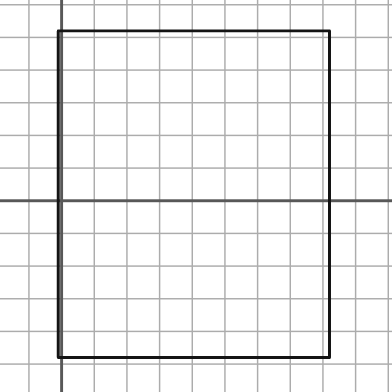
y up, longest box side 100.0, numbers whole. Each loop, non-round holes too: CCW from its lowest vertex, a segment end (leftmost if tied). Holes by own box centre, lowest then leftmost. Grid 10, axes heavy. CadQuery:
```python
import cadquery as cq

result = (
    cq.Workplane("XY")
    .moveTo(-1.0, -48.0)
    .lineTo(82.0, -48.0)
    .lineTo(82.0, 52.0)
    .lineTo(-1.0, 52.0)
    .close()
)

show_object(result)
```